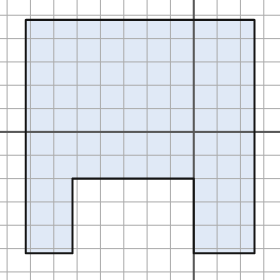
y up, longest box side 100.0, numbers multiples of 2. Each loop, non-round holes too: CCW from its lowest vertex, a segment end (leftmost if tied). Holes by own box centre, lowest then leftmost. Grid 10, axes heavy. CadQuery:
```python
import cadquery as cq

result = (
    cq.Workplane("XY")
    .moveTo(-72.0, -52.0)
    .lineTo(-52.0, -52.0)
    .lineTo(-52.0, -20.0)
    .lineTo(0.0, -20.0)
    .lineTo(0.0, -52.0)
    .lineTo(26.0, -52.0)
    .lineTo(26.0, 48.0)
    .lineTo(-72.0, 48.0)
    .close()
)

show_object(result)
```